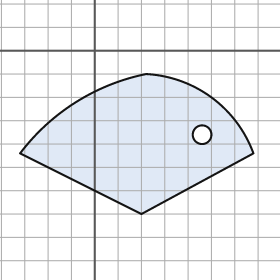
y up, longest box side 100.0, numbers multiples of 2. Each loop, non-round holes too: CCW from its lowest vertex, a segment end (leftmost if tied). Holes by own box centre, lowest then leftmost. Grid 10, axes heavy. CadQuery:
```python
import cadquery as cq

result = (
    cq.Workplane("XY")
    .moveTo(20.0, -70.0)
    .lineTo(68.0, -44.0)
    .threePointArc((50.0, -20.0), (22.0, -10.0))
    .threePointArc((-8.0, -22.0), (-32.0, -44.0))
    .close()
    .moveTo(46.0, -36.0)
    .circle(4.0)
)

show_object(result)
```